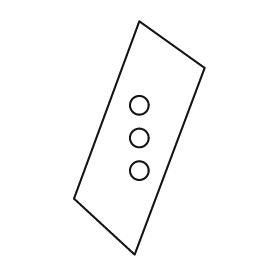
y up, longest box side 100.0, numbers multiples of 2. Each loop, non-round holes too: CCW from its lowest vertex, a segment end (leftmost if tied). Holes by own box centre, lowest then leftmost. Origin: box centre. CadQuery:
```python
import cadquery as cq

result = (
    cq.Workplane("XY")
    .moveTo(-2.0, -50.0)
    .lineTo(28.0, 30.0)
    .lineTo(0.0, 50.0)
    .lineTo(-28.0, -26.0)
    .close()
    .moveTo(0.0, -14.0)
    .circle(4.0)
    .moveTo(0.0, 0.0)
    .circle(4.0)
    .moveTo(0.0, 14.0)
    .circle(4.0)
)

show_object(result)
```